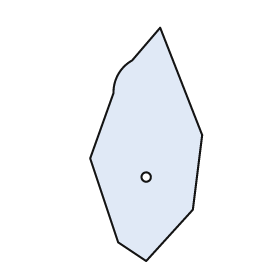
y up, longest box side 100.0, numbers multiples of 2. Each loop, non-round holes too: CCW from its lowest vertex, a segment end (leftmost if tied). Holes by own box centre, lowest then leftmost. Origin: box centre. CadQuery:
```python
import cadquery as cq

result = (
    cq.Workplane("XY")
    .moveTo(0.0, -50.0)
    .lineTo(20.0, -28.0)
    .lineTo(24.0, 4.0)
    .lineTo(6.0, 50.0)
    .lineTo(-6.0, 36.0)
    .threePointArc((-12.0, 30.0), (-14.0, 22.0))
    .lineTo(-24.0, -6.0)
    .lineTo(-12.0, -42.0)
    .close()
    .moveTo(0.0, -14.0)
    .circle(2.0)
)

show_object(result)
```